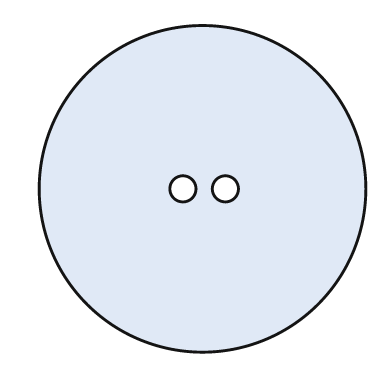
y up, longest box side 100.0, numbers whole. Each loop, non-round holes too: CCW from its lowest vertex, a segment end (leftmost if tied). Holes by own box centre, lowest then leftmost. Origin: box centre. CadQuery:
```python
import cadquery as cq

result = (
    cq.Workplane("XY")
    .moveTo(0.0, 0.0)
    .circle(50.0)
    .moveTo(-6.0, 0.0)
    .circle(4.0)
    .moveTo(7.0, 0.0)
    .circle(4.0)
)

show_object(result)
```